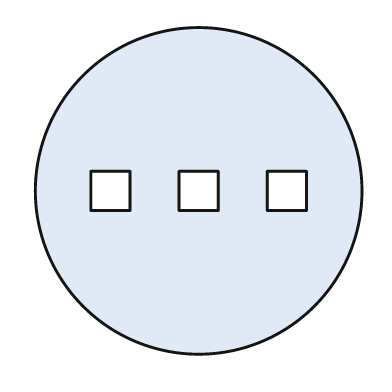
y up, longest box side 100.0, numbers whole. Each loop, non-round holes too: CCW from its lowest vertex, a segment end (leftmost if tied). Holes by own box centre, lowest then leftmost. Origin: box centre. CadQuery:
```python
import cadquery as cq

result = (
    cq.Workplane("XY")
    .moveTo(0.0, 0.0)
    .circle(50.0)
    .moveTo(-33.0, -6.0)
    .lineTo(-21.0, -6.0)
    .lineTo(-21.0, 6.0)
    .lineTo(-33.0, 6.0)
    .close()
    .moveTo(-6.0, -6.0)
    .lineTo(6.0, -6.0)
    .lineTo(6.0, 6.0)
    .lineTo(-6.0, 6.0)
    .close()
    .moveTo(21.0, -6.0)
    .lineTo(33.0, -6.0)
    .lineTo(33.0, 6.0)
    .lineTo(21.0, 6.0)
    .close()
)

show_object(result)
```